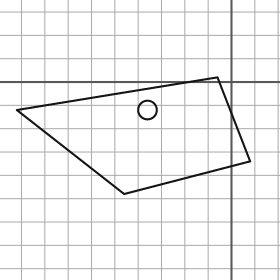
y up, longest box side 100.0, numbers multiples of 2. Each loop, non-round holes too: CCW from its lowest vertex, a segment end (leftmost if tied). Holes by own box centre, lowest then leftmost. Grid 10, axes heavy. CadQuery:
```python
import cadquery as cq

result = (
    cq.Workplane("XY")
    .moveTo(-46.0, -48.0)
    .lineTo(8.0, -34.0)
    .lineTo(-6.0, 2.0)
    .lineTo(-92.0, -12.0)
    .close()
    .moveTo(-36.0, -12.0)
    .circle(4.0)
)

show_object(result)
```